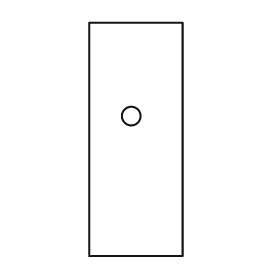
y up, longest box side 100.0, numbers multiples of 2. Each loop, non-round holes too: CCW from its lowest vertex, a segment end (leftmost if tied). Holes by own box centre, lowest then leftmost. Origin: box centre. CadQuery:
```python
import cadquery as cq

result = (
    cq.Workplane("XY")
    .moveTo(-20.0, -50.0)
    .lineTo(20.0, -50.0)
    .lineTo(20.0, 50.0)
    .lineTo(-20.0, 50.0)
    .close()
    .moveTo(-2.0, 10.0)
    .circle(4.0)
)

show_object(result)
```